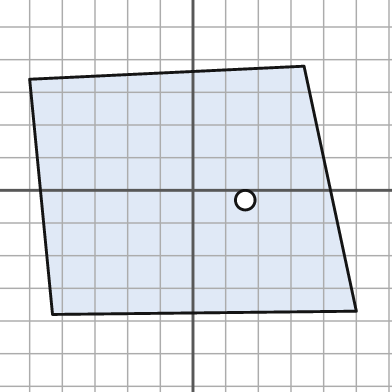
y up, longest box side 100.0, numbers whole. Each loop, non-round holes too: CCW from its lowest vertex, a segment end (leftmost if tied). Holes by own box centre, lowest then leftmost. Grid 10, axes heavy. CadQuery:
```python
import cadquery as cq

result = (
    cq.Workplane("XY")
    .moveTo(-43.0, -38.0)
    .lineTo(50.0, -37.0)
    .lineTo(34.0, 38.0)
    .lineTo(-50.0, 34.0)
    .close()
    .moveTo(16.0, -3.0)
    .circle(3.0)
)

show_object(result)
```